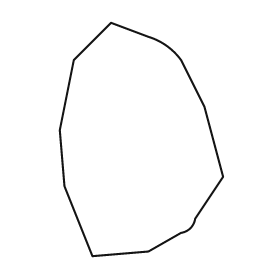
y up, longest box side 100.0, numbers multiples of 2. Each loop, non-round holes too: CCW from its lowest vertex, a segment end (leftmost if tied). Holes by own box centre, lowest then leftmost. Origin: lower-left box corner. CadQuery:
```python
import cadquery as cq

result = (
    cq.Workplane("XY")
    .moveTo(14.0, 0.0)
    .lineTo(38.0, 2.0)
    .lineTo(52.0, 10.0)
    .threePointArc((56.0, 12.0), (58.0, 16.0))
    .lineTo(70.0, 34.0)
    .lineTo(62.0, 64.0)
    .lineTo(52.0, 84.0)
    .threePointArc((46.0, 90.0), (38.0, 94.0))
    .lineTo(22.0, 100.0)
    .lineTo(6.0, 84.0)
    .lineTo(0.0, 54.0)
    .lineTo(2.0, 30.0)
    .close()
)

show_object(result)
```